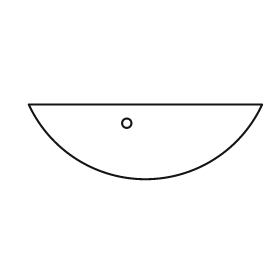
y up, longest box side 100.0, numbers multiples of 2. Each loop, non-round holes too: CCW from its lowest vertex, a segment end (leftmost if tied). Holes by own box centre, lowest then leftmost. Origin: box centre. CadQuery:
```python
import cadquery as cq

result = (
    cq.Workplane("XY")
    .moveTo(-50.0, 16.0)
    .threePointArc((0.0, -16.0), (50.0, 16.0))
    .close()
    .moveTo(-8.0, 8.0)
    .circle(2.0)
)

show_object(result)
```